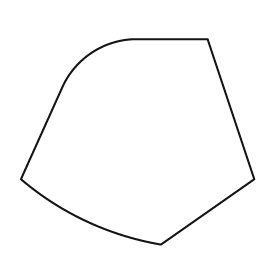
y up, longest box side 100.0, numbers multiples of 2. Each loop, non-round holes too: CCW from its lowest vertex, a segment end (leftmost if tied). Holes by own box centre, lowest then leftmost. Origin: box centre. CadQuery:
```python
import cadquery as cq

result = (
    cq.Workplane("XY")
    .moveTo(10.0, -44.0)
    .lineTo(50.0, -16.0)
    .lineTo(30.0, 44.0)
    .lineTo(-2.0, 44.0)
    .threePointArc((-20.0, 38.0), (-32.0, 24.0))
    .lineTo(-50.0, -16.0)
    .threePointArc((-22.0, -34.0), (10.0, -44.0))
    .close()
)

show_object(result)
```